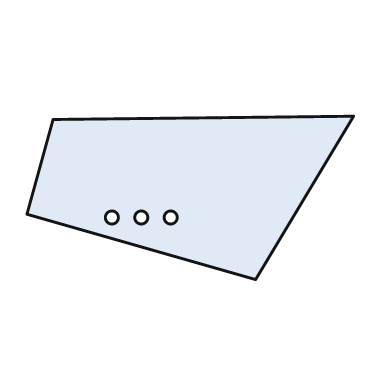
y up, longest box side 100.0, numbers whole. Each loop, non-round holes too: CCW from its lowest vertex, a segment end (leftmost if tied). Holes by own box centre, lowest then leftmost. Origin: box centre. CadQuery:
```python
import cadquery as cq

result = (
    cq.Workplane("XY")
    .moveTo(20.0, -25.0)
    .lineTo(50.0, 25.0)
    .lineTo(-42.0, 24.0)
    .lineTo(-50.0, -5.0)
    .close()
    .moveTo(-24.0, -6.0)
    .circle(2.0)
    .moveTo(-15.0, -6.0)
    .circle(2.0)
    .moveTo(-6.0, -6.0)
    .circle(2.0)
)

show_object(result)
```